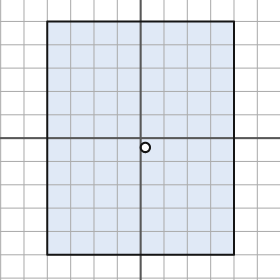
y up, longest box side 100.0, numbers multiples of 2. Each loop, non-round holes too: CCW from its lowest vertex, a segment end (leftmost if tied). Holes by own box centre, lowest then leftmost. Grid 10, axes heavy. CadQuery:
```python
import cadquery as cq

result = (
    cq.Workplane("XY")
    .moveTo(-40.0, -50.0)
    .lineTo(40.0, -50.0)
    .lineTo(40.0, 50.0)
    .lineTo(-40.0, 50.0)
    .close()
    .moveTo(2.0, -4.0)
    .circle(2.0)
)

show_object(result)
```